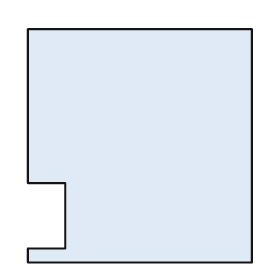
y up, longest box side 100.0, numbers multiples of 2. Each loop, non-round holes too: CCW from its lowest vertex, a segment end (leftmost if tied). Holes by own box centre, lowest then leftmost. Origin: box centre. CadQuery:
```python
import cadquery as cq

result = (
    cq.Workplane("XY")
    .moveTo(-48.0, -50.0)
    .lineTo(48.0, -50.0)
    .lineTo(48.0, 50.0)
    .lineTo(-48.0, 50.0)
    .lineTo(-48.0, -16.0)
    .lineTo(-32.0, -16.0)
    .lineTo(-32.0, -44.0)
    .lineTo(-48.0, -44.0)
    .close()
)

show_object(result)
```